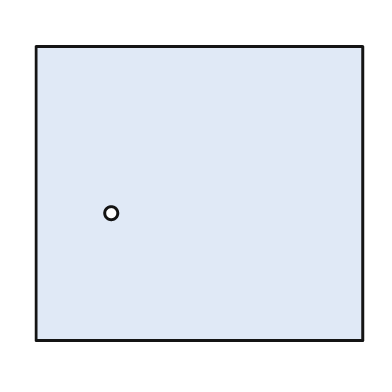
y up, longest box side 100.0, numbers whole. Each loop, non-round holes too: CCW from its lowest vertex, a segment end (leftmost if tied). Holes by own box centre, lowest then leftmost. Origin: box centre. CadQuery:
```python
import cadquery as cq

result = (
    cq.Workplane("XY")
    .moveTo(-50.0, -45.0)
    .lineTo(50.0, -45.0)
    .lineTo(50.0, 45.0)
    .lineTo(-50.0, 45.0)
    .close()
    .moveTo(-27.0, -6.0)
    .circle(2.0)
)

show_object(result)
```